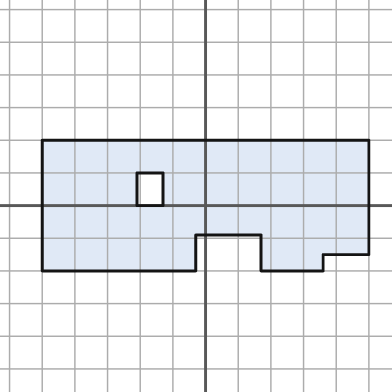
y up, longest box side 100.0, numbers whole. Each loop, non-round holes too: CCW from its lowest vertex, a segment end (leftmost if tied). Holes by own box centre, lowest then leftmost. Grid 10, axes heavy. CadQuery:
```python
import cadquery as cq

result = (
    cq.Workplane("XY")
    .moveTo(-50.0, -20.0)
    .lineTo(-3.0, -20.0)
    .lineTo(-3.0, -9.0)
    .lineTo(17.0, -9.0)
    .lineTo(17.0, -20.0)
    .lineTo(36.0, -20.0)
    .lineTo(36.0, -15.0)
    .lineTo(50.0, -15.0)
    .lineTo(50.0, 20.0)
    .lineTo(-50.0, 20.0)
    .close()
    .moveTo(-21.0, 0.0)
    .lineTo(-13.0, 0.0)
    .lineTo(-13.0, 10.0)
    .lineTo(-21.0, 10.0)
    .close()
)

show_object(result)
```